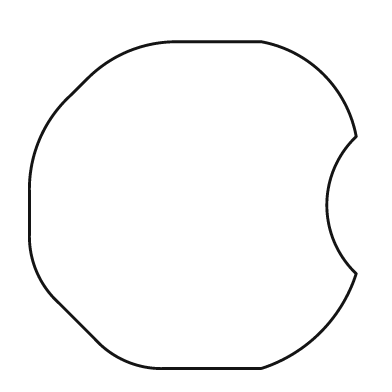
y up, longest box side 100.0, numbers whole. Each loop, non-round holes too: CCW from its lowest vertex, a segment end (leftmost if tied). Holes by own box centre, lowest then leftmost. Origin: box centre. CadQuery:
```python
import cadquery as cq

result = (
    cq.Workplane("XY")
    .moveTo(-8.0, -50.0)
    .lineTo(21.0, -50.0)
    .threePointArc((39.0, -39.0), (50.0, -21.0))
    .threePointArc((41.0, 0.0), (50.0, 21.0))
    .threePointArc((40.0, 40.0), (21.0, 50.0))
    .lineTo(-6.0, 50.0)
    .threePointArc((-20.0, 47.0), (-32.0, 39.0))
    .lineTo(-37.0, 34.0)
    .threePointArc((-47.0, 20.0), (-50.0, 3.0))
    .lineTo(-50.0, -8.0)
    .threePointArc((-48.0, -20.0), (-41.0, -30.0))
    .lineTo(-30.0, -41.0)
    .threePointArc((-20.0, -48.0), (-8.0, -50.0))
    .close()
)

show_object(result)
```